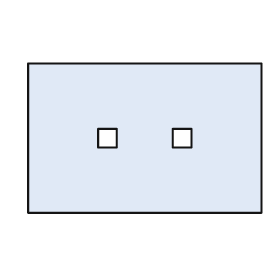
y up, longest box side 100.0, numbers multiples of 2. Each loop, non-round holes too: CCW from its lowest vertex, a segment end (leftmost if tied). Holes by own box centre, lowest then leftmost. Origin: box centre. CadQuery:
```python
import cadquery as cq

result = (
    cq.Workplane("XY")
    .moveTo(-50.0, -32.0)
    .lineTo(50.0, -32.0)
    .lineTo(50.0, 32.0)
    .lineTo(-50.0, 32.0)
    .close()
    .moveTo(-20.0, -4.0)
    .lineTo(-12.0, -4.0)
    .lineTo(-12.0, 4.0)
    .lineTo(-20.0, 4.0)
    .close()
    .moveTo(12.0, -4.0)
    .lineTo(20.0, -4.0)
    .lineTo(20.0, 4.0)
    .lineTo(12.0, 4.0)
    .close()
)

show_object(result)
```